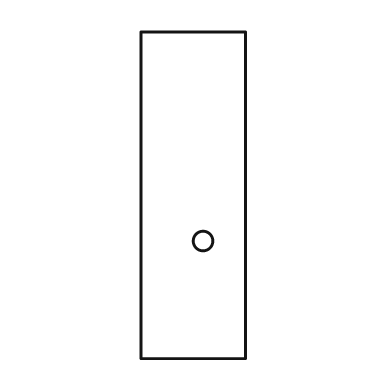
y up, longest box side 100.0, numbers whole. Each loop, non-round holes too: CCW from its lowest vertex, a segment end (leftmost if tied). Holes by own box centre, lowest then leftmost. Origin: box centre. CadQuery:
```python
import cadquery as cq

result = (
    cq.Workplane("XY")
    .moveTo(-16.0, -50.0)
    .lineTo(16.0, -50.0)
    .lineTo(16.0, 50.0)
    .lineTo(-16.0, 50.0)
    .close()
    .moveTo(3.0, -14.0)
    .circle(3.0)
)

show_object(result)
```